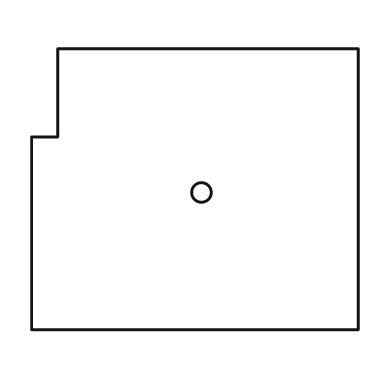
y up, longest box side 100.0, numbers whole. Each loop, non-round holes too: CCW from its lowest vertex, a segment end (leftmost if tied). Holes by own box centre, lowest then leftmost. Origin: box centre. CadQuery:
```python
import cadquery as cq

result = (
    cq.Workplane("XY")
    .moveTo(-50.0, -43.0)
    .lineTo(50.0, -43.0)
    .lineTo(50.0, 43.0)
    .lineTo(-42.0, 43.0)
    .lineTo(-42.0, 16.0)
    .lineTo(-50.0, 16.0)
    .close()
    .moveTo(2.0, -1.0)
    .circle(3.0)
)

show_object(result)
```